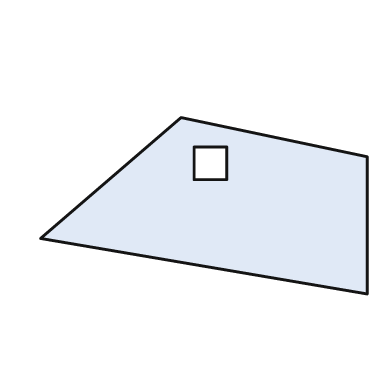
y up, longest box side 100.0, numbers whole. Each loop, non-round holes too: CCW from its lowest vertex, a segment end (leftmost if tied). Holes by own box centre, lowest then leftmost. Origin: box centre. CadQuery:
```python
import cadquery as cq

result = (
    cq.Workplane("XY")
    .moveTo(50.0, -27.0)
    .lineTo(50.0, 15.0)
    .lineTo(-7.0, 27.0)
    .lineTo(-50.0, -10.0)
    .close()
    .moveTo(-3.0, 8.0)
    .lineTo(7.0, 8.0)
    .lineTo(7.0, 18.0)
    .lineTo(-3.0, 18.0)
    .close()
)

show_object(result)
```